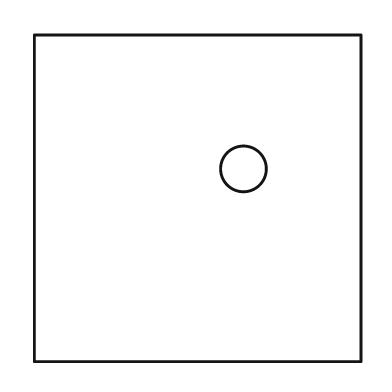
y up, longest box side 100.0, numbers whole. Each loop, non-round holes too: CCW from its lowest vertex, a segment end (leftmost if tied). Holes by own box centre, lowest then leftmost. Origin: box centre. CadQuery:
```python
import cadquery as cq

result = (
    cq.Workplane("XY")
    .moveTo(-50.0, -50.0)
    .lineTo(50.0, -50.0)
    .lineTo(50.0, 50.0)
    .lineTo(-50.0, 50.0)
    .close()
    .moveTo(14.0, 9.0)
    .circle(7.0)
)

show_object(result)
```